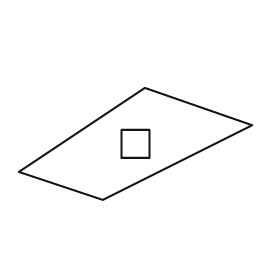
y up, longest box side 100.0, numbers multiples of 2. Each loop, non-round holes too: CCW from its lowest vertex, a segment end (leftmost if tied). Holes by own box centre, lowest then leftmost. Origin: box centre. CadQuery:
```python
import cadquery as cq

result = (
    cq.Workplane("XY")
    .moveTo(-14.0, -24.0)
    .lineTo(50.0, 8.0)
    .lineTo(4.0, 24.0)
    .lineTo(-50.0, -12.0)
    .close()
    .moveTo(-6.0, -6.0)
    .lineTo(6.0, -6.0)
    .lineTo(6.0, 6.0)
    .lineTo(-6.0, 6.0)
    .close()
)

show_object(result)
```